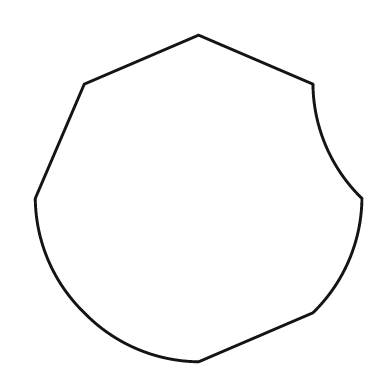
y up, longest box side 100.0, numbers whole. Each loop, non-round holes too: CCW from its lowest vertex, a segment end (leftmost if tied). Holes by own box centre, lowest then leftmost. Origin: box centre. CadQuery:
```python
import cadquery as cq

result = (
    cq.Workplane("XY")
    .moveTo(0.0, -50.0)
    .lineTo(35.0, -35.0)
    .threePointArc((46.0, -19.0), (50.0, 0.0))
    .threePointArc((39.0, 16.0), (35.0, 35.0))
    .lineTo(0.0, 50.0)
    .lineTo(-35.0, 35.0)
    .lineTo(-50.0, 0.0)
    .threePointArc((-46.0, -19.0), (-35.0, -35.0))
    .threePointArc((-19.0, -46.0), (0.0, -50.0))
    .close()
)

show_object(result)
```